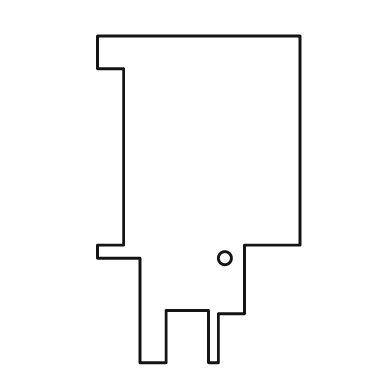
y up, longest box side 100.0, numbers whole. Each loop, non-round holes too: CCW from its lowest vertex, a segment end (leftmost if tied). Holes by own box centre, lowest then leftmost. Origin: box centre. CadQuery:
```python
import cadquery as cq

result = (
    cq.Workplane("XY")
    .moveTo(-18.0, -50.0)
    .lineTo(-10.0, -50.0)
    .lineTo(-10.0, -34.0)
    .lineTo(3.0, -34.0)
    .lineTo(3.0, -50.0)
    .lineTo(6.0, -50.0)
    .lineTo(6.0, -35.0)
    .lineTo(14.0, -35.0)
    .lineTo(14.0, -14.0)
    .lineTo(31.0, -14.0)
    .lineTo(31.0, 50.0)
    .lineTo(-31.0, 50.0)
    .lineTo(-31.0, 40.0)
    .lineTo(-23.0, 40.0)
    .lineTo(-23.0, -14.0)
    .lineTo(-31.0, -14.0)
    .lineTo(-31.0, -18.0)
    .lineTo(-18.0, -18.0)
    .close()
    .moveTo(8.0, -18.0)
    .circle(2.0)
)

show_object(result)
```